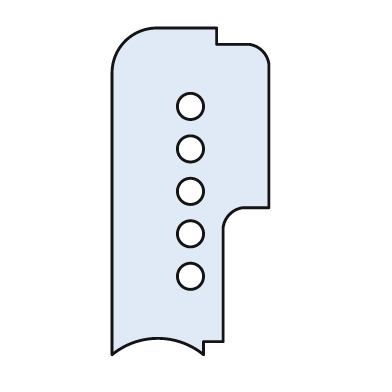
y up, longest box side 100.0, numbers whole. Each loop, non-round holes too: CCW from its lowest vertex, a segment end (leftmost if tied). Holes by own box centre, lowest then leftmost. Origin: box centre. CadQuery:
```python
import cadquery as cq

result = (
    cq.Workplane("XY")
    .moveTo(-24.0, -50.0)
    .threePointArc((-10.0, -45.0), (4.0, -50.0))
    .lineTo(4.0, -46.0)
    .lineTo(10.0, -46.0)
    .lineTo(10.0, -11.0)
    .threePointArc((12.0, -7.0), (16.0, -5.0))
    .lineTo(24.0, -5.0)
    .lineTo(24.0, 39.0)
    .threePointArc((22.0, 43.0), (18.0, 45.0))
    .lineTo(8.0, 45.0)
    .lineTo(8.0, 50.0)
    .lineTo(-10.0, 50.0)
    .threePointArc((-20.0, 46.0), (-24.0, 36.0))
    .close()
    .moveTo(0.0, -26.0)
    .circle(4.0)
    .moveTo(0.0, -13.0)
    .circle(4.0)
    .moveTo(0.0, 0.0)
    .circle(4.0)
    .moveTo(0.0, 13.0)
    .circle(4.0)
    .moveTo(0.0, 26.0)
    .circle(4.0)
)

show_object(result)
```